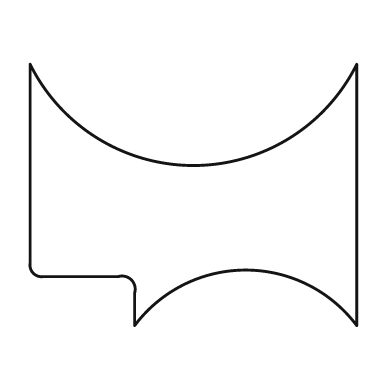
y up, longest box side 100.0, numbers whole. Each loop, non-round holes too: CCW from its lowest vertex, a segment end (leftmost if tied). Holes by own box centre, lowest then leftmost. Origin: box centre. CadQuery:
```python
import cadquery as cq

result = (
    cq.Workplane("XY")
    .moveTo(-18.0, -40.0)
    .threePointArc((16.0, -23.0), (50.0, -40.0))
    .lineTo(50.0, 40.0)
    .threePointArc((0.0, 9.0), (-50.0, 40.0))
    .lineTo(-50.0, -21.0)
    .threePointArc((-49.0, -24.0), (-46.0, -25.0))
    .lineTo(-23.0, -25.0)
    .threePointArc((-19.0, -26.0), (-18.0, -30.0))
    .close()
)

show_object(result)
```